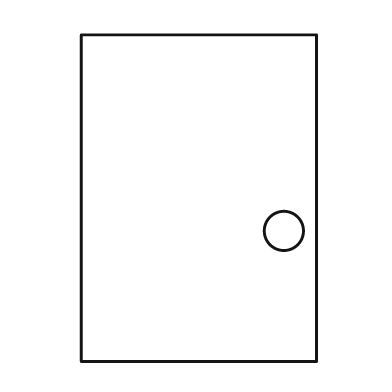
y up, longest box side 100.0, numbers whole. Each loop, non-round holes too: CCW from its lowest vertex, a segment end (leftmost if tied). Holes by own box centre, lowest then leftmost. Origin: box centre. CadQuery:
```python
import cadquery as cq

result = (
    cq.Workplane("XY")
    .moveTo(-36.0, -50.0)
    .lineTo(36.0, -50.0)
    .lineTo(36.0, 50.0)
    .lineTo(-36.0, 50.0)
    .close()
    .moveTo(26.0, -10.0)
    .circle(6.0)
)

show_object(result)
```